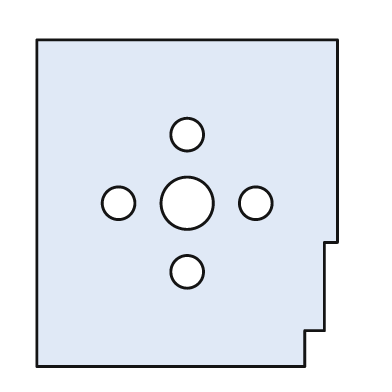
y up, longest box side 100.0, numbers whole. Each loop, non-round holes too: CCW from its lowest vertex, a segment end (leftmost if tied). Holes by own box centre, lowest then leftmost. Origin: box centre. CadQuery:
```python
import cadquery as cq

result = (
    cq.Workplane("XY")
    .moveTo(-46.0, -50.0)
    .lineTo(36.0, -50.0)
    .lineTo(36.0, -39.0)
    .lineTo(42.0, -39.0)
    .lineTo(42.0, -12.0)
    .lineTo(46.0, -12.0)
    .lineTo(46.0, 50.0)
    .lineTo(-46.0, 50.0)
    .close()
    .moveTo(0.0, -21.0)
    .circle(5.0)
    .moveTo(-21.0, 0.0)
    .circle(5.0)
    .moveTo(0.0, 0.0)
    .circle(8.0)
    .moveTo(21.0, 0.0)
    .circle(5.0)
    .moveTo(0.0, 21.0)
    .circle(5.0)
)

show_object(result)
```